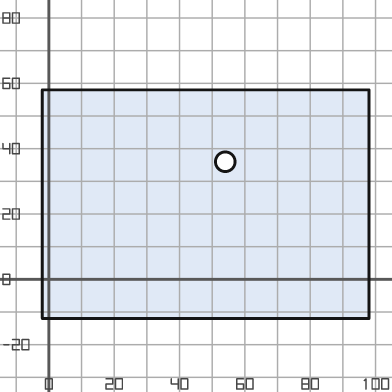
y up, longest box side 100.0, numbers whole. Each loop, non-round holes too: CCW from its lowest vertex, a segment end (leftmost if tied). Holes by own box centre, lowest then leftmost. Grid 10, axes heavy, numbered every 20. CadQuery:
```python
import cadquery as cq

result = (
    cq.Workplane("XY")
    .moveTo(-2.0, -12.0)
    .lineTo(98.0, -12.0)
    .lineTo(98.0, 58.0)
    .lineTo(-2.0, 58.0)
    .close()
    .moveTo(54.0, 36.0)
    .circle(3.0)
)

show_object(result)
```